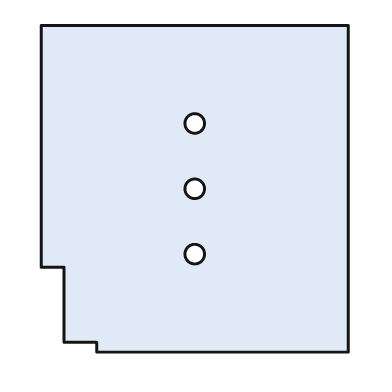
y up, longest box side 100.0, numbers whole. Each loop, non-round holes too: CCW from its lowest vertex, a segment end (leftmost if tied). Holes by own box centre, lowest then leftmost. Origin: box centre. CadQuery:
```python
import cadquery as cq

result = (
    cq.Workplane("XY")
    .moveTo(-30.0, -50.0)
    .lineTo(47.0, -50.0)
    .lineTo(47.0, 50.0)
    .lineTo(-47.0, 50.0)
    .lineTo(-47.0, -24.0)
    .lineTo(-40.0, -24.0)
    .lineTo(-40.0, -47.0)
    .lineTo(-30.0, -47.0)
    .close()
    .moveTo(0.0, -20.0)
    .circle(3.0)
    .moveTo(0.0, 0.0)
    .circle(3.0)
    .moveTo(0.0, 20.0)
    .circle(3.0)
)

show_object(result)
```